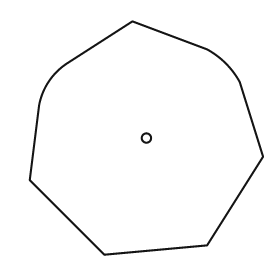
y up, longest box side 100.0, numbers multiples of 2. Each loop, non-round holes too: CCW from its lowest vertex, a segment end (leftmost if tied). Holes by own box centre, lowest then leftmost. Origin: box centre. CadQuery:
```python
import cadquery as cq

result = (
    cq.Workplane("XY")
    .moveTo(-18.0, -50.0)
    .lineTo(26.0, -46.0)
    .lineTo(50.0, -8.0)
    .lineTo(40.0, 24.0)
    .threePointArc((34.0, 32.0), (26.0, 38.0))
    .lineTo(-6.0, 50.0)
    .lineTo(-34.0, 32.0)
    .threePointArc((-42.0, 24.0), (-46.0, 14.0))
    .lineTo(-50.0, -18.0)
    .close()
    .moveTo(0.0, 0.0)
    .circle(2.0)
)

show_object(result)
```